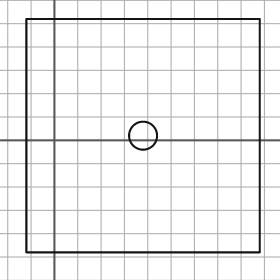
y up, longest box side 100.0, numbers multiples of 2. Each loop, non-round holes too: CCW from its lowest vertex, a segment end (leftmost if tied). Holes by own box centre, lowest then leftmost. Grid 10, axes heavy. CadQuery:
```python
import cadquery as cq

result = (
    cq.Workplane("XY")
    .moveTo(-12.0, -48.0)
    .lineTo(88.0, -48.0)
    .lineTo(88.0, 52.0)
    .lineTo(-12.0, 52.0)
    .close()
    .moveTo(38.0, 2.0)
    .circle(6.0)
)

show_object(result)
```